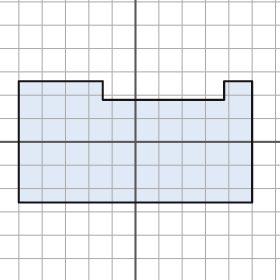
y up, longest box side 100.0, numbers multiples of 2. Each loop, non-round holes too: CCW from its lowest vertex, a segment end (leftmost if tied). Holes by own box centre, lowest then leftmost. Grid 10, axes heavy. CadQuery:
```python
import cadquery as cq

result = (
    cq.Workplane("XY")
    .moveTo(-50.0, -26.0)
    .lineTo(50.0, -26.0)
    .lineTo(50.0, 26.0)
    .lineTo(38.0, 26.0)
    .lineTo(38.0, 18.0)
    .lineTo(-14.0, 18.0)
    .lineTo(-14.0, 26.0)
    .lineTo(-50.0, 26.0)
    .close()
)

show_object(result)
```